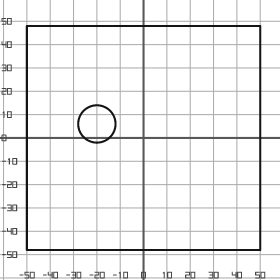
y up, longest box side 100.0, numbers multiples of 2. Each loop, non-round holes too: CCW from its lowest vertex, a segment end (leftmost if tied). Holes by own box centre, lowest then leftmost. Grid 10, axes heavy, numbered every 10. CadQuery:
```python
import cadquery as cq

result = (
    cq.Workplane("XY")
    .moveTo(-50.0, -48.0)
    .lineTo(50.0, -48.0)
    .lineTo(50.0, 48.0)
    .lineTo(-50.0, 48.0)
    .close()
    .moveTo(-20.0, 6.0)
    .circle(8.0)
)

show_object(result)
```